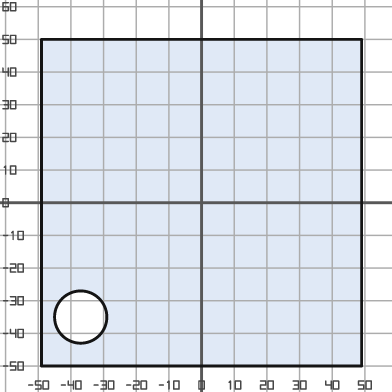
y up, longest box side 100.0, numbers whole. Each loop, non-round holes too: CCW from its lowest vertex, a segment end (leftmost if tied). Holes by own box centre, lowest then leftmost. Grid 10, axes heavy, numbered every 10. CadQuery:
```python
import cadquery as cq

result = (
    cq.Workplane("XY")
    .moveTo(-49.0, -50.0)
    .lineTo(49.0, -50.0)
    .lineTo(49.0, 50.0)
    .lineTo(-49.0, 50.0)
    .close()
    .moveTo(-37.0, -35.0)
    .circle(8.0)
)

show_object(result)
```